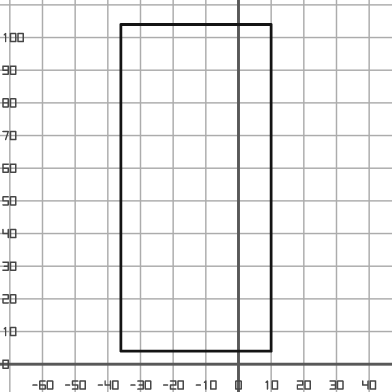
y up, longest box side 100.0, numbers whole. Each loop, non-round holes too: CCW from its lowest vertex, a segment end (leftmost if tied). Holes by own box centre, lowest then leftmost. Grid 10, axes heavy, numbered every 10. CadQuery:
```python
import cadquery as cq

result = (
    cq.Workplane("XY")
    .moveTo(-36.0, 4.0)
    .lineTo(10.0, 4.0)
    .lineTo(10.0, 104.0)
    .lineTo(-36.0, 104.0)
    .close()
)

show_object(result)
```